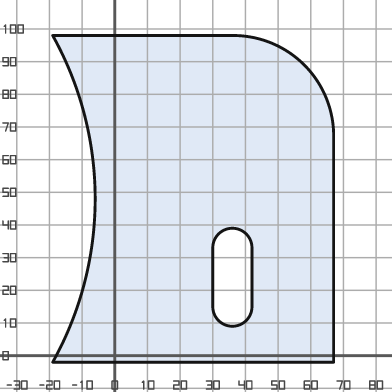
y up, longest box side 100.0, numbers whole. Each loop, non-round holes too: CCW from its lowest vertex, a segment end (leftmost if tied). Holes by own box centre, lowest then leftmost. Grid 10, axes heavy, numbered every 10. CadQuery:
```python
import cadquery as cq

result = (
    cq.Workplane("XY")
    .moveTo(-19.0, -2.0)
    .lineTo(67.0, -2.0)
    .lineTo(67.0, 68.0)
    .threePointArc((58.0, 89.0), (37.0, 98.0))
    .lineTo(-19.0, 98.0)
    .threePointArc((-6.0, 48.0), (-19.0, -2.0))
    .close()
    .moveTo(30.0, 15.0)
    .threePointArc((36.0, 9.0), (42.0, 15.0))
    .lineTo(42.0, 33.0)
    .threePointArc((36.0, 39.0), (30.0, 33.0))
    .close()
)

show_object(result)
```